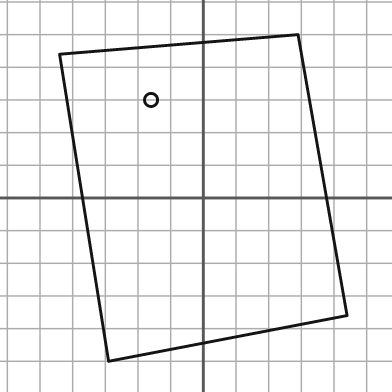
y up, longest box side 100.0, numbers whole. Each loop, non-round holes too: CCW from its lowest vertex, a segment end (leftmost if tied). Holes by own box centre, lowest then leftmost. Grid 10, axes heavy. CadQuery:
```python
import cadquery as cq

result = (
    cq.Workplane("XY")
    .moveTo(-29.0, -50.0)
    .lineTo(44.0, -36.0)
    .lineTo(29.0, 50.0)
    .lineTo(-44.0, 44.0)
    .close()
    .moveTo(-16.0, 30.0)
    .circle(2.0)
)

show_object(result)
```